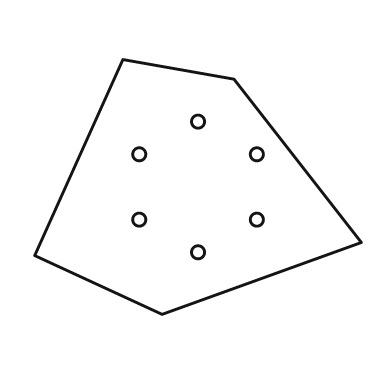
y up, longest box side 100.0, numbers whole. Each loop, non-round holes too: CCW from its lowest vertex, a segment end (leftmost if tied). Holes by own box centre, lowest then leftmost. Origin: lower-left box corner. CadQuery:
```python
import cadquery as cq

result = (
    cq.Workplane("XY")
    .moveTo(39.0, 0.0)
    .lineTo(100.0, 22.0)
    .lineTo(61.0, 72.0)
    .lineTo(27.0, 78.0)
    .lineTo(0.0, 18.0)
    .close()
    .moveTo(50.0, 19.0)
    .circle(2.0)
    .moveTo(32.0, 29.0)
    .circle(2.0)
    .moveTo(68.0, 29.0)
    .circle(2.0)
    .moveTo(32.0, 49.0)
    .circle(2.0)
    .moveTo(68.0, 49.0)
    .circle(2.0)
    .moveTo(50.0, 59.0)
    .circle(2.0)
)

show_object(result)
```